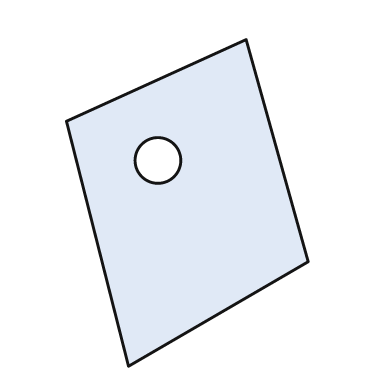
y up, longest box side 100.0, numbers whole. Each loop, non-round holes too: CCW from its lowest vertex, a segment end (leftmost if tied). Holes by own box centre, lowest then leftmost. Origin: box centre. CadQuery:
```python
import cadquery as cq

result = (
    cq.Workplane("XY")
    .moveTo(-18.0, -50.0)
    .lineTo(37.0, -18.0)
    .lineTo(18.0, 50.0)
    .lineTo(-37.0, 25.0)
    .close()
    .moveTo(-9.0, 13.0)
    .circle(7.0)
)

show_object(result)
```